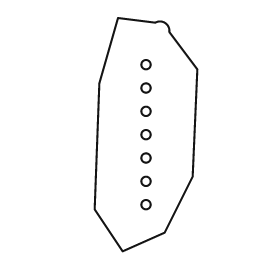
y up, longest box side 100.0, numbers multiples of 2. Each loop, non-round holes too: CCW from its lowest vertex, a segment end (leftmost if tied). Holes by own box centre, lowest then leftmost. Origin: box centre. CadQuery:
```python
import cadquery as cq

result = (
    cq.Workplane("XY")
    .moveTo(-10.0, -50.0)
    .lineTo(8.0, -42.0)
    .lineTo(20.0, -18.0)
    .lineTo(22.0, 28.0)
    .lineTo(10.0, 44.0)
    .threePointArc((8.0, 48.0), (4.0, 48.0))
    .lineTo(-12.0, 50.0)
    .lineTo(-20.0, 22.0)
    .lineTo(-22.0, -32.0)
    .close()
    .moveTo(0.0, -30.0)
    .circle(2.0)
    .moveTo(0.0, -20.0)
    .circle(2.0)
    .moveTo(0.0, -10.0)
    .circle(2.0)
    .moveTo(0.0, 0.0)
    .circle(2.0)
    .moveTo(0.0, 10.0)
    .circle(2.0)
    .moveTo(0.0, 20.0)
    .circle(2.0)
    .moveTo(0.0, 30.0)
    .circle(2.0)
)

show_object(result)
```